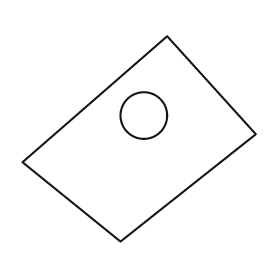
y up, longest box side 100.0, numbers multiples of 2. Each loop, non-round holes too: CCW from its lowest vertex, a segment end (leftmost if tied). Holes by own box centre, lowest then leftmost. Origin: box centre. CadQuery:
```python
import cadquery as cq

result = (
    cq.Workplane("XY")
    .moveTo(-8.0, -44.0)
    .lineTo(50.0, 2.0)
    .lineTo(12.0, 44.0)
    .lineTo(-50.0, -10.0)
    .close()
    .moveTo(2.0, 10.0)
    .circle(10.0)
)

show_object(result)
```